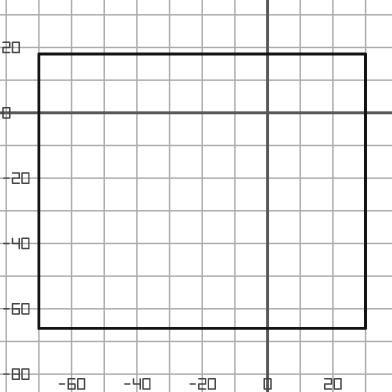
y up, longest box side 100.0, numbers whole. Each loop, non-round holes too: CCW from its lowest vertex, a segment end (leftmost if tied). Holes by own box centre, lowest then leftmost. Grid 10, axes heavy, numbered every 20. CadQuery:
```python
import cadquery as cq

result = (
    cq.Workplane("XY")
    .moveTo(-70.0, -66.0)
    .lineTo(30.0, -66.0)
    .lineTo(30.0, 18.0)
    .lineTo(-70.0, 18.0)
    .close()
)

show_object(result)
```